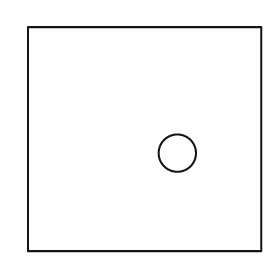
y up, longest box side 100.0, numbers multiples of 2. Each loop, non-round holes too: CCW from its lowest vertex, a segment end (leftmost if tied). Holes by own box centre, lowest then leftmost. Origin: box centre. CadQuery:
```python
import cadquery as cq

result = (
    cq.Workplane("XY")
    .moveTo(-50.0, -48.0)
    .lineTo(50.0, -48.0)
    .lineTo(50.0, 48.0)
    .lineTo(-50.0, 48.0)
    .close()
    .moveTo(14.0, -6.0)
    .circle(8.0)
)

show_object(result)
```